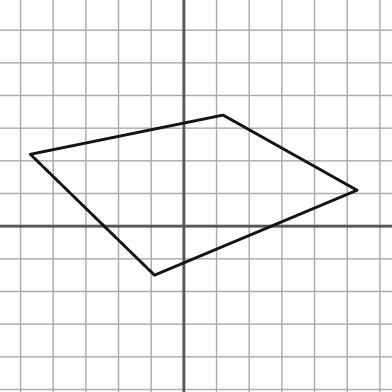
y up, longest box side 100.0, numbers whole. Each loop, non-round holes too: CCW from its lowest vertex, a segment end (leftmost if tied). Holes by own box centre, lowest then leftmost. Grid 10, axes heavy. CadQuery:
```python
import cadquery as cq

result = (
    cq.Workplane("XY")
    .moveTo(-9.0, -15.0)
    .lineTo(53.0, 11.0)
    .lineTo(12.0, 34.0)
    .lineTo(-47.0, 22.0)
    .close()
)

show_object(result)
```